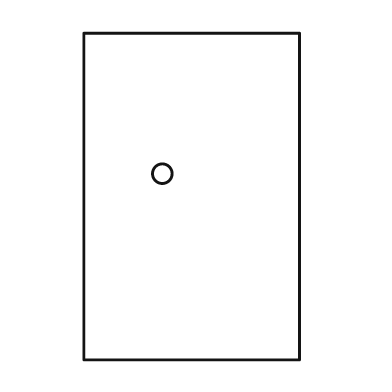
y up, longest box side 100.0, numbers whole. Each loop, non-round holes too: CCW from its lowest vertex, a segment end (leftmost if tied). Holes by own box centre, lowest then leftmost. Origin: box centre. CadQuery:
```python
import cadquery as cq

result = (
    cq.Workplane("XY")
    .moveTo(-33.0, -50.0)
    .lineTo(33.0, -50.0)
    .lineTo(33.0, 50.0)
    .lineTo(-33.0, 50.0)
    .close()
    .moveTo(-9.0, 7.0)
    .circle(3.0)
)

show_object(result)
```